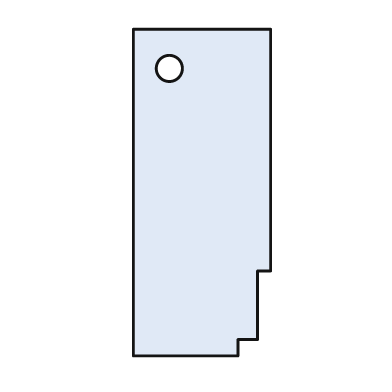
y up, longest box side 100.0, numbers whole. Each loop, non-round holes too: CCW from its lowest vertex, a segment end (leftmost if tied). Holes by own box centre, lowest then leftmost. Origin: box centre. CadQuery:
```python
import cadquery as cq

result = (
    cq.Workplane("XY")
    .moveTo(-21.0, -50.0)
    .lineTo(11.0, -50.0)
    .lineTo(11.0, -45.0)
    .lineTo(17.0, -45.0)
    .lineTo(17.0, -24.0)
    .lineTo(21.0, -24.0)
    .lineTo(21.0, 50.0)
    .lineTo(-21.0, 50.0)
    .close()
    .moveTo(-10.0, 38.0)
    .circle(4.0)
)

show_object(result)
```